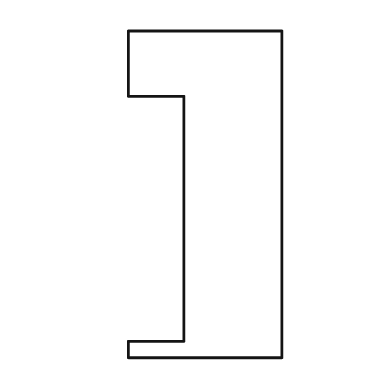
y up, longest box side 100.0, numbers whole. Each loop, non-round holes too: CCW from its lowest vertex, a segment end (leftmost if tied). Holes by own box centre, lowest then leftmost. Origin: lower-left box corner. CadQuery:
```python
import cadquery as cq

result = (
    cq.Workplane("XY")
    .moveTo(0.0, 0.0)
    .lineTo(47.0, 0.0)
    .lineTo(47.0, 100.0)
    .lineTo(0.0, 100.0)
    .lineTo(0.0, 80.0)
    .lineTo(17.0, 80.0)
    .lineTo(17.0, 5.0)
    .lineTo(0.0, 5.0)
    .close()
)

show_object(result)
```